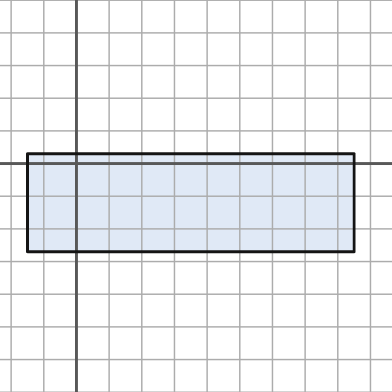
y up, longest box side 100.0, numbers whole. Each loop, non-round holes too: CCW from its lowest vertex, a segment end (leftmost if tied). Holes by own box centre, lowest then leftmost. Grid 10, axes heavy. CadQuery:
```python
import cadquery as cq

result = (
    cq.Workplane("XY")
    .moveTo(-15.0, -27.0)
    .lineTo(85.0, -27.0)
    .lineTo(85.0, 3.0)
    .lineTo(-15.0, 3.0)
    .close()
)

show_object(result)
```